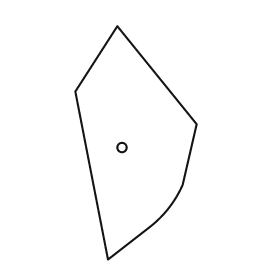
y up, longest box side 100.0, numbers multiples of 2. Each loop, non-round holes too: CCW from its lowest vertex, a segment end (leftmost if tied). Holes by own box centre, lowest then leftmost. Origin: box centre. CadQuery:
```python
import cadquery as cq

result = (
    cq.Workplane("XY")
    .moveTo(-12.0, -50.0)
    .lineTo(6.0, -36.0)
    .threePointArc((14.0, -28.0), (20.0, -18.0))
    .lineTo(26.0, 8.0)
    .lineTo(-8.0, 50.0)
    .lineTo(-26.0, 22.0)
    .close()
    .moveTo(-6.0, -2.0)
    .circle(2.0)
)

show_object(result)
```